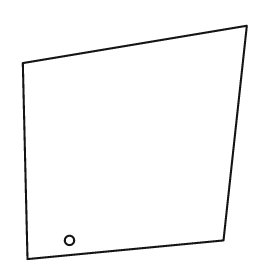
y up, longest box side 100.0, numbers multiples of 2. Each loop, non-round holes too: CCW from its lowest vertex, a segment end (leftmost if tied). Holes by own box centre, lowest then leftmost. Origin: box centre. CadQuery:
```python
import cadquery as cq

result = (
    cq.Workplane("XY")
    .moveTo(-46.0, -50.0)
    .lineTo(38.0, -42.0)
    .lineTo(48.0, 50.0)
    .lineTo(-48.0, 34.0)
    .close()
    .moveTo(-28.0, -42.0)
    .circle(2.0)
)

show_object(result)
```